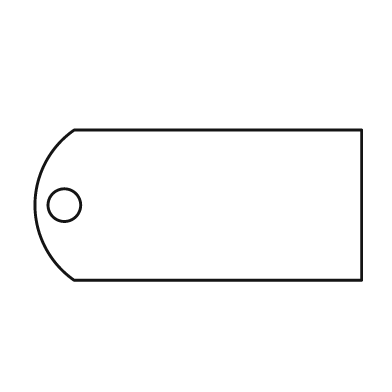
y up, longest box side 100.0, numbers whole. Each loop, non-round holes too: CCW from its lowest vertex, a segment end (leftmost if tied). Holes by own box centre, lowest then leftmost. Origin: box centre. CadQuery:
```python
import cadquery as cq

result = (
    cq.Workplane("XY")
    .moveTo(-38.0, -23.0)
    .lineTo(50.0, -23.0)
    .lineTo(50.0, 23.0)
    .lineTo(-38.0, 23.0)
    .threePointArc((-50.0, 0.0), (-38.0, -23.0))
    .close()
    .moveTo(-41.0, 0.0)
    .circle(5.0)
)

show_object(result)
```